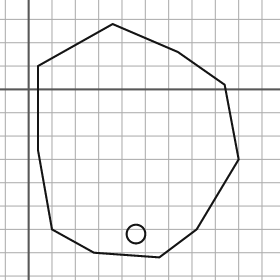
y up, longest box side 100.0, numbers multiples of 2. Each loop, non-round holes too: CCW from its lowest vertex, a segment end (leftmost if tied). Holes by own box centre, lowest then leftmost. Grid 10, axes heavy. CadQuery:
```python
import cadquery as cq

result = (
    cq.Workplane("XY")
    .moveTo(56.0, -72.0)
    .lineTo(72.0, -60.0)
    .lineTo(90.0, -30.0)
    .lineTo(84.0, 2.0)
    .lineTo(64.0, 16.0)
    .lineTo(36.0, 28.0)
    .lineTo(4.0, 10.0)
    .lineTo(4.0, -26.0)
    .lineTo(10.0, -60.0)
    .lineTo(28.0, -70.0)
    .close()
    .moveTo(46.0, -62.0)
    .circle(4.0)
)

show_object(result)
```